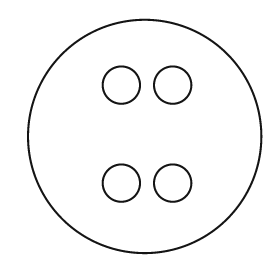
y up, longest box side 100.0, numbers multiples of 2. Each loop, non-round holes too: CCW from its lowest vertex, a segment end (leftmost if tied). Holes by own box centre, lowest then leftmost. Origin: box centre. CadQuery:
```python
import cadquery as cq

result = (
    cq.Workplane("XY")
    .moveTo(0.0, 0.0)
    .circle(50.0)
    .moveTo(-10.0, -20.0)
    .circle(8.0)
    .moveTo(12.0, -20.0)
    .circle(8.0)
    .moveTo(-10.0, 22.0)
    .circle(8.0)
    .moveTo(12.0, 22.0)
    .circle(8.0)
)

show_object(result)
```